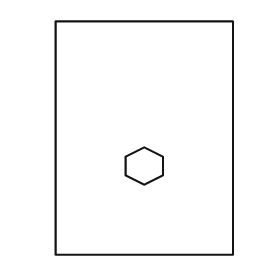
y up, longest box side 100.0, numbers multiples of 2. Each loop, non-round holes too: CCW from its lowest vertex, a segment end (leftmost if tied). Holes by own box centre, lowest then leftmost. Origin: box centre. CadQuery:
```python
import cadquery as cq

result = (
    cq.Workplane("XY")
    .moveTo(-38.0, -50.0)
    .lineTo(38.0, -50.0)
    .lineTo(38.0, 50.0)
    .lineTo(-38.0, 50.0)
    .close()
    .moveTo(0.0, -20.0)
    .lineTo(8.0, -16.0)
    .lineTo(8.0, -8.0)
    .lineTo(0.0, -4.0)
    .lineTo(-8.0, -8.0)
    .lineTo(-8.0, -16.0)
    .close()
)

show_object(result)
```